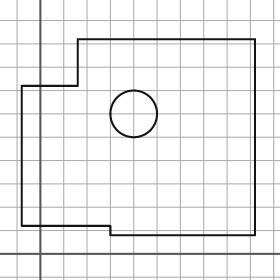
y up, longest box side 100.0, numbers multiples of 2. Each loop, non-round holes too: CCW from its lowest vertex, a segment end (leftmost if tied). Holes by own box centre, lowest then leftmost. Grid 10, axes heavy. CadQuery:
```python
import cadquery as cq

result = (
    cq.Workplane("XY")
    .moveTo(30.0, 8.0)
    .lineTo(92.0, 8.0)
    .lineTo(92.0, 92.0)
    .lineTo(16.0, 92.0)
    .lineTo(16.0, 72.0)
    .lineTo(-8.0, 72.0)
    .lineTo(-8.0, 12.0)
    .lineTo(30.0, 12.0)
    .close()
    .moveTo(40.0, 60.0)
    .circle(10.0)
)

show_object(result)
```